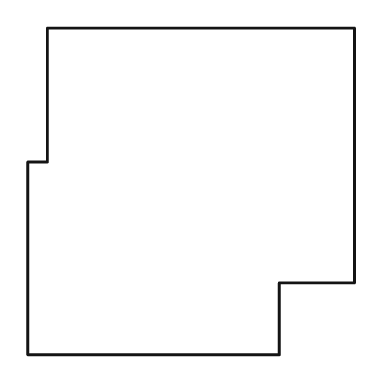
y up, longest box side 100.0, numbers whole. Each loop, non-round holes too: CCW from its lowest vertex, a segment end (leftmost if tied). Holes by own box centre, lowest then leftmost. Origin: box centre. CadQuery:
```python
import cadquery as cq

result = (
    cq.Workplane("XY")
    .moveTo(-50.0, -50.0)
    .lineTo(27.0, -50.0)
    .lineTo(27.0, -28.0)
    .lineTo(50.0, -28.0)
    .lineTo(50.0, 50.0)
    .lineTo(-44.0, 50.0)
    .lineTo(-44.0, 9.0)
    .lineTo(-50.0, 9.0)
    .close()
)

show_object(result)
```